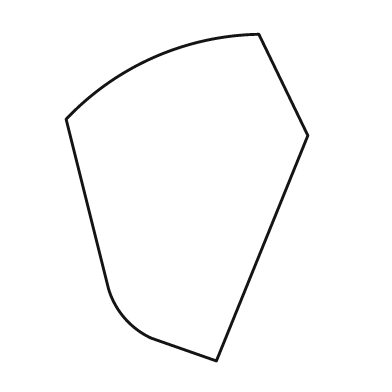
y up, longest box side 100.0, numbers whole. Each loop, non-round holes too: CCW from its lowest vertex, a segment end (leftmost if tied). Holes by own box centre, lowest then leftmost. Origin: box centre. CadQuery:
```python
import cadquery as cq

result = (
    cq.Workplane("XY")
    .moveTo(9.0, -50.0)
    .lineTo(37.0, 19.0)
    .lineTo(22.0, 50.0)
    .threePointArc((-10.0, 43.0), (-37.0, 24.0))
    .lineTo(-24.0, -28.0)
    .threePointArc((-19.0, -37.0), (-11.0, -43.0))
    .close()
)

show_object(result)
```